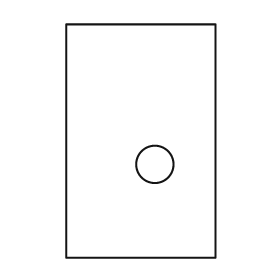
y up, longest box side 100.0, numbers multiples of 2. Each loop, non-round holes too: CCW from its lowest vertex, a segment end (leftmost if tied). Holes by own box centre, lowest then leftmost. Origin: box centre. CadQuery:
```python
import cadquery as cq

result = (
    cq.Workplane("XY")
    .moveTo(-32.0, -50.0)
    .lineTo(32.0, -50.0)
    .lineTo(32.0, 50.0)
    .lineTo(-32.0, 50.0)
    .close()
    .moveTo(6.0, -10.0)
    .circle(8.0)
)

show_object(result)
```